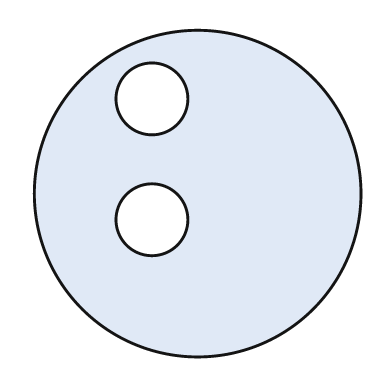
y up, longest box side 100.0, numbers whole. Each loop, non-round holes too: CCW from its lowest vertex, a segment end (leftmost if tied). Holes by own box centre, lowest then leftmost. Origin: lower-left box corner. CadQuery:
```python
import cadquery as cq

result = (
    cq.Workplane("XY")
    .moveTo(50.0, 50.0)
    .circle(50.0)
    .moveTo(36.0, 42.0)
    .circle(11.0)
    .moveTo(36.0, 79.0)
    .circle(11.0)
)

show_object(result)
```